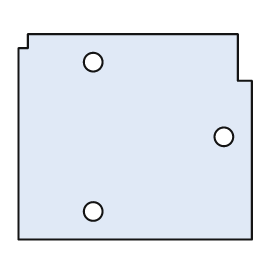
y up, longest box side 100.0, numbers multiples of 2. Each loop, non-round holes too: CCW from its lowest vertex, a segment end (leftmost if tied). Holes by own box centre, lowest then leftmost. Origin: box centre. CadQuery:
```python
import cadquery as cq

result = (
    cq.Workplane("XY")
    .moveTo(-50.0, -44.0)
    .lineTo(50.0, -44.0)
    .lineTo(50.0, 24.0)
    .lineTo(44.0, 24.0)
    .lineTo(44.0, 44.0)
    .lineTo(-46.0, 44.0)
    .lineTo(-46.0, 38.0)
    .lineTo(-50.0, 38.0)
    .close()
    .moveTo(-18.0, -32.0)
    .circle(4.0)
    .moveTo(38.0, 0.0)
    .circle(4.0)
    .moveTo(-18.0, 32.0)
    .circle(4.0)
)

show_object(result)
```